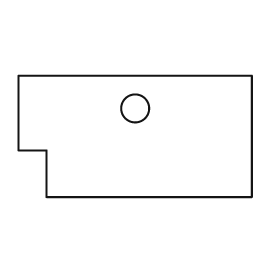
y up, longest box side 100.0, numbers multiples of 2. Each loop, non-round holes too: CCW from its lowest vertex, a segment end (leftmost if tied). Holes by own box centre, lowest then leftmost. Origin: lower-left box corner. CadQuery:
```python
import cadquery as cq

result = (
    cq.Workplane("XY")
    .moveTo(12.0, 0.0)
    .lineTo(100.0, 0.0)
    .lineTo(100.0, 52.0)
    .lineTo(0.0, 52.0)
    .lineTo(0.0, 20.0)
    .lineTo(12.0, 20.0)
    .close()
    .moveTo(50.0, 38.0)
    .circle(6.0)
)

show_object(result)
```